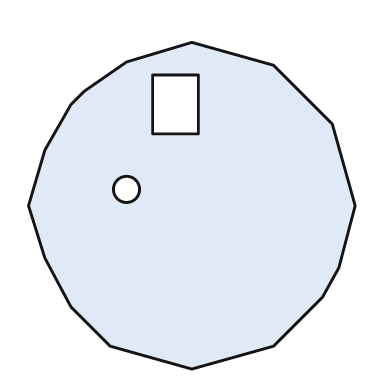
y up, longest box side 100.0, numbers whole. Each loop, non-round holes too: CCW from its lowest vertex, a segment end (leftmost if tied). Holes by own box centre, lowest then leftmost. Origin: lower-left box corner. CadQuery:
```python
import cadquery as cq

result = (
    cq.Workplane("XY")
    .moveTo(50.0, 0.0)
    .lineTo(75.0, 7.0)
    .lineTo(90.0, 22.0)
    .lineTo(95.0, 31.0)
    .lineTo(100.0, 50.0)
    .lineTo(93.0, 75.0)
    .lineTo(75.0, 93.0)
    .lineTo(50.0, 100.0)
    .lineTo(30.0, 94.0)
    .lineTo(17.0, 85.0)
    .lineTo(13.0, 81.0)
    .lineTo(5.0, 67.0)
    .lineTo(0.0, 50.0)
    .lineTo(5.0, 34.0)
    .lineTo(13.0, 19.0)
    .lineTo(25.0, 7.0)
    .close()
    .moveTo(30.0, 55.0)
    .circle(4.0)
    .moveTo(38.0, 72.0)
    .lineTo(52.0, 72.0)
    .lineTo(52.0, 90.0)
    .lineTo(38.0, 90.0)
    .close()
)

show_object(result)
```